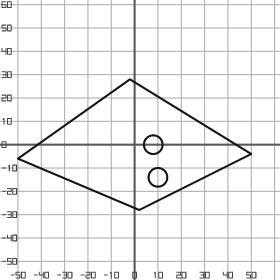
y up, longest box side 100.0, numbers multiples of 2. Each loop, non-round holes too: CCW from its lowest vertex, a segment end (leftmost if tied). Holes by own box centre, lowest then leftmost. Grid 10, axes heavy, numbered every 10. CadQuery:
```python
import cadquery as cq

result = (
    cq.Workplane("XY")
    .moveTo(2.0, -28.0)
    .lineTo(50.0, -4.0)
    .lineTo(-2.0, 28.0)
    .lineTo(-50.0, -6.0)
    .close()
    .moveTo(10.0, -14.0)
    .circle(4.0)
    .moveTo(8.0, 0.0)
    .circle(4.0)
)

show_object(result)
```